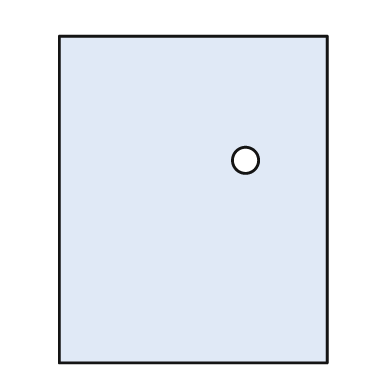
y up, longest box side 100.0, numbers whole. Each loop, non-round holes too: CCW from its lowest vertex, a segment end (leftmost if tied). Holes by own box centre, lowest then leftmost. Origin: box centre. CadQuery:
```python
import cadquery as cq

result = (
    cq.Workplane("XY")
    .moveTo(-41.0, -50.0)
    .lineTo(41.0, -50.0)
    .lineTo(41.0, 50.0)
    .lineTo(-41.0, 50.0)
    .close()
    .moveTo(16.0, 12.0)
    .circle(4.0)
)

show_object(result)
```